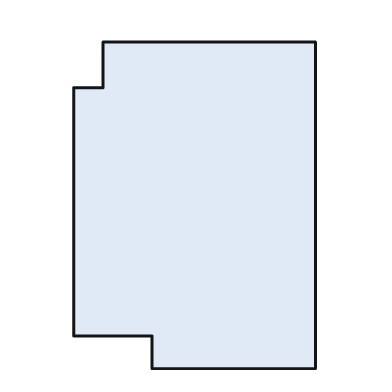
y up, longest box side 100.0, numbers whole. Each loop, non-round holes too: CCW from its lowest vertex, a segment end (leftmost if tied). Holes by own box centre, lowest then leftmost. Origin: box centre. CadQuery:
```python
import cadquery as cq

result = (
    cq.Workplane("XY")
    .moveTo(-13.0, -50.0)
    .lineTo(37.0, -50.0)
    .lineTo(37.0, 50.0)
    .lineTo(-28.0, 50.0)
    .lineTo(-28.0, 36.0)
    .lineTo(-37.0, 36.0)
    .lineTo(-37.0, -40.0)
    .lineTo(-13.0, -40.0)
    .close()
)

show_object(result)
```